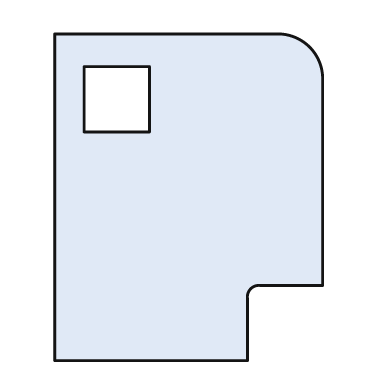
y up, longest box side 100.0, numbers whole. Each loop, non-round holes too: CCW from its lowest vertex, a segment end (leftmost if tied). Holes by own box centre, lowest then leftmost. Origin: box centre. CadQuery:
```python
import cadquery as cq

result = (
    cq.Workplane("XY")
    .moveTo(-41.0, -50.0)
    .lineTo(18.0, -50.0)
    .lineTo(18.0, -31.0)
    .threePointArc((19.0, -28.0), (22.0, -27.0))
    .lineTo(41.0, -27.0)
    .lineTo(41.0, 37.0)
    .threePointArc((37.0, 46.0), (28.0, 50.0))
    .lineTo(-41.0, 50.0)
    .close()
    .moveTo(-32.0, 20.0)
    .lineTo(-12.0, 20.0)
    .lineTo(-12.0, 40.0)
    .lineTo(-32.0, 40.0)
    .close()
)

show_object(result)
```